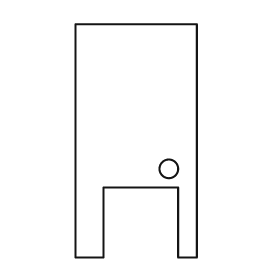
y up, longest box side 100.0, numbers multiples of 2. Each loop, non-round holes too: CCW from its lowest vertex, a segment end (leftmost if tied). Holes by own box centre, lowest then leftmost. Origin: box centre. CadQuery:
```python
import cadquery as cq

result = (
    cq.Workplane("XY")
    .moveTo(-26.0, -50.0)
    .lineTo(-14.0, -50.0)
    .lineTo(-14.0, -20.0)
    .lineTo(18.0, -20.0)
    .lineTo(18.0, -50.0)
    .lineTo(26.0, -50.0)
    .lineTo(26.0, 50.0)
    .lineTo(-26.0, 50.0)
    .close()
    .moveTo(14.0, -12.0)
    .circle(4.0)
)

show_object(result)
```